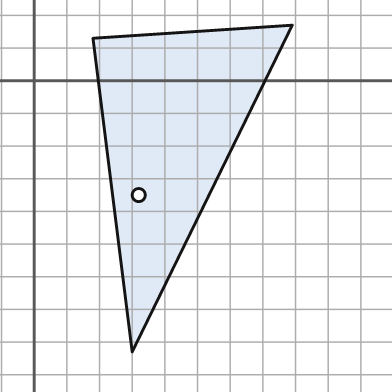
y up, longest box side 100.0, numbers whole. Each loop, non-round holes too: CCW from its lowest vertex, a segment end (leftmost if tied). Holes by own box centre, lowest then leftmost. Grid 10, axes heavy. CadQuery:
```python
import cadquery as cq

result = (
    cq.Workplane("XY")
    .moveTo(30.0, -83.0)
    .lineTo(79.0, 17.0)
    .lineTo(18.0, 13.0)
    .close()
    .moveTo(32.0, -35.0)
    .circle(2.0)
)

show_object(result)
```